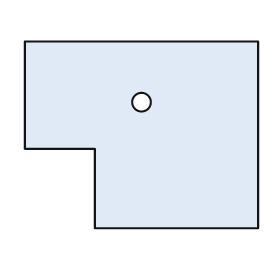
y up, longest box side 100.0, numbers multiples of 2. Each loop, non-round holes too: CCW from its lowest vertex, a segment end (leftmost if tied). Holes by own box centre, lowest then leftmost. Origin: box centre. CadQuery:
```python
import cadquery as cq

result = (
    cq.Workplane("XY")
    .moveTo(-20.0, -40.0)
    .lineTo(50.0, -40.0)
    .lineTo(50.0, 40.0)
    .lineTo(-50.0, 40.0)
    .lineTo(-50.0, -6.0)
    .lineTo(-20.0, -6.0)
    .close()
    .moveTo(0.0, 14.0)
    .circle(4.0)
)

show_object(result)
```